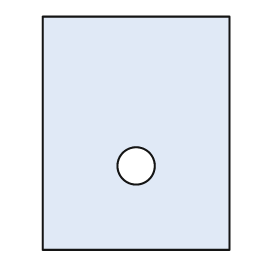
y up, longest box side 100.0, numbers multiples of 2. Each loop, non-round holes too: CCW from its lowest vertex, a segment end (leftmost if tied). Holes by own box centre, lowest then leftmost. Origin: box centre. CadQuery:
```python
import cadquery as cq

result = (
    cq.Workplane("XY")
    .moveTo(-40.0, -50.0)
    .lineTo(40.0, -50.0)
    .lineTo(40.0, 50.0)
    .lineTo(-40.0, 50.0)
    .close()
    .moveTo(0.0, -14.0)
    .circle(8.0)
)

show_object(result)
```